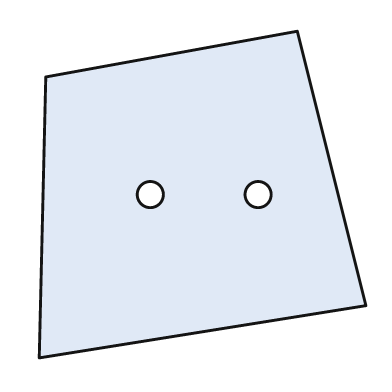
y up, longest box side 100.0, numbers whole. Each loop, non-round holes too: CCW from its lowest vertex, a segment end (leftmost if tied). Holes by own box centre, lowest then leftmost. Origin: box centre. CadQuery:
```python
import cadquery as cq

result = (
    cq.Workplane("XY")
    .moveTo(-50.0, -50.0)
    .lineTo(50.0, -34.0)
    .lineTo(29.0, 50.0)
    .lineTo(-48.0, 36.0)
    .close()
    .moveTo(-16.0, 0.0)
    .circle(4.0)
    .moveTo(17.0, 0.0)
    .circle(4.0)
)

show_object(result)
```